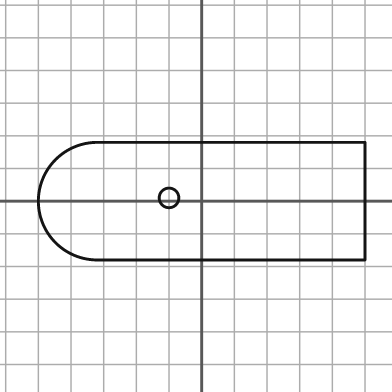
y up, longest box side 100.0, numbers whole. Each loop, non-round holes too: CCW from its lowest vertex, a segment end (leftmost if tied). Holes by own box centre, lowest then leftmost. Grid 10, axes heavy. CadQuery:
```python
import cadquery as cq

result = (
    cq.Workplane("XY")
    .moveTo(-32.0, -18.0)
    .lineTo(50.0, -18.0)
    .lineTo(50.0, 18.0)
    .lineTo(-32.0, 18.0)
    .threePointArc((-50.0, 0.0), (-32.0, -18.0))
    .close()
    .moveTo(-10.0, 1.0)
    .circle(3.0)
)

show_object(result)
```